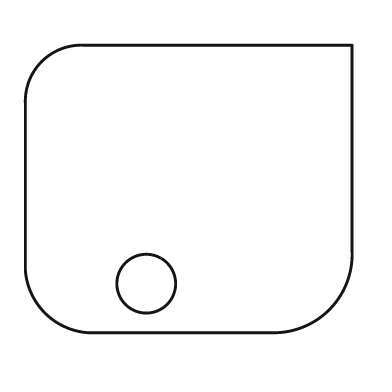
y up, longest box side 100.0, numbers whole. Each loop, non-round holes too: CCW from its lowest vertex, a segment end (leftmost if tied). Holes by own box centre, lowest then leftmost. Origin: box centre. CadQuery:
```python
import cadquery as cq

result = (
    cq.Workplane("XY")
    .moveTo(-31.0, -44.0)
    .lineTo(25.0, -44.0)
    .threePointArc((43.0, -37.0), (50.0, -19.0))
    .lineTo(50.0, 44.0)
    .lineTo(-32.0, 44.0)
    .threePointArc((-45.0, 39.0), (-50.0, 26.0))
    .lineTo(-50.0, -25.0)
    .threePointArc((-44.0, -38.0), (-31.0, -44.0))
    .close()
    .moveTo(-13.0, -29.0)
    .circle(9.0)
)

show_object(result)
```